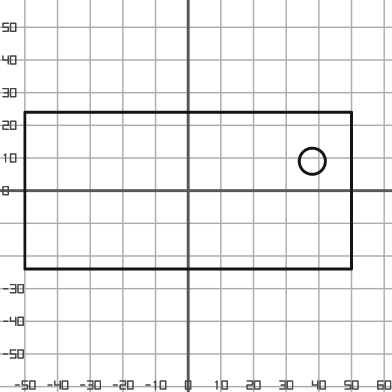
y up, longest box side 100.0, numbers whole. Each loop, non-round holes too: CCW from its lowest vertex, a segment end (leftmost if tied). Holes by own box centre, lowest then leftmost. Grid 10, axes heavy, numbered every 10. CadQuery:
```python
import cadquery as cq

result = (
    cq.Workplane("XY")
    .moveTo(-50.0, -24.0)
    .lineTo(50.0, -24.0)
    .lineTo(50.0, 24.0)
    .lineTo(-50.0, 24.0)
    .close()
    .moveTo(38.0, 9.0)
    .circle(4.0)
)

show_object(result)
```